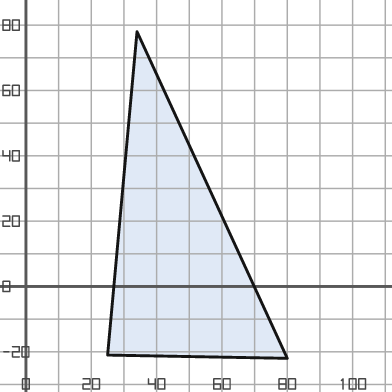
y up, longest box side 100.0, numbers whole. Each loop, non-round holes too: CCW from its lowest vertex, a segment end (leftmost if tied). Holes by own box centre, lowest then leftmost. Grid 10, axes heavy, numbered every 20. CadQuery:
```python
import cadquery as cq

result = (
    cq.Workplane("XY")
    .moveTo(80.0, -22.0)
    .lineTo(34.0, 78.0)
    .lineTo(25.0, -21.0)
    .close()
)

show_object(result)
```